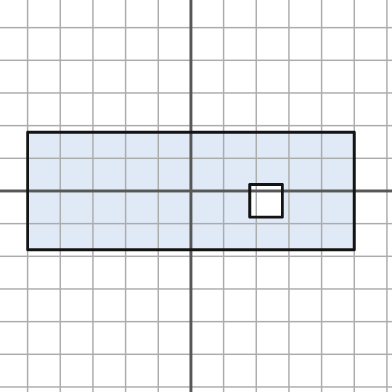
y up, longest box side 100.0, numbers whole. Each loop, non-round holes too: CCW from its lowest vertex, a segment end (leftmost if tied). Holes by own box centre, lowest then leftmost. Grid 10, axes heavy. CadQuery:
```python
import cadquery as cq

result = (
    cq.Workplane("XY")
    .moveTo(-50.0, -18.0)
    .lineTo(50.0, -18.0)
    .lineTo(50.0, 18.0)
    .lineTo(-50.0, 18.0)
    .close()
    .moveTo(18.0, -8.0)
    .lineTo(28.0, -8.0)
    .lineTo(28.0, 2.0)
    .lineTo(18.0, 2.0)
    .close()
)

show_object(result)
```